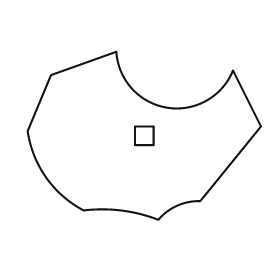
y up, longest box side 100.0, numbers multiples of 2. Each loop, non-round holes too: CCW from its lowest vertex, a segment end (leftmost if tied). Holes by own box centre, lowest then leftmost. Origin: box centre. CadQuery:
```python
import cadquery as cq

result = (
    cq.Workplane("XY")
    .moveTo(6.0, -36.0)
    .threePointArc((14.0, -30.0), (24.0, -28.0))
    .lineTo(50.0, 4.0)
    .lineTo(38.0, 28.0)
    .threePointArc((10.0, 12.0), (-12.0, 36.0))
    .lineTo(-40.0, 26.0)
    .lineTo(-50.0, 2.0)
    .threePointArc((-42.0, -18.0), (-26.0, -32.0))
    .threePointArc((-10.0, -32.0), (6.0, -36.0))
    .close()
    .moveTo(-4.0, -4.0)
    .lineTo(4.0, -4.0)
    .lineTo(4.0, 4.0)
    .lineTo(-4.0, 4.0)
    .close()
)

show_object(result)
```